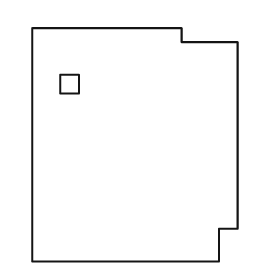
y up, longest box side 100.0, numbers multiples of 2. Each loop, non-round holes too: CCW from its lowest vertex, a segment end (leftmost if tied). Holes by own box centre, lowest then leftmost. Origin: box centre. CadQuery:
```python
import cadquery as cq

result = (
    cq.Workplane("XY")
    .moveTo(-44.0, -50.0)
    .lineTo(36.0, -50.0)
    .lineTo(36.0, -36.0)
    .lineTo(44.0, -36.0)
    .lineTo(44.0, 44.0)
    .lineTo(20.0, 44.0)
    .lineTo(20.0, 50.0)
    .lineTo(-44.0, 50.0)
    .close()
    .moveTo(-32.0, 22.0)
    .lineTo(-24.0, 22.0)
    .lineTo(-24.0, 30.0)
    .lineTo(-32.0, 30.0)
    .close()
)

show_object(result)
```